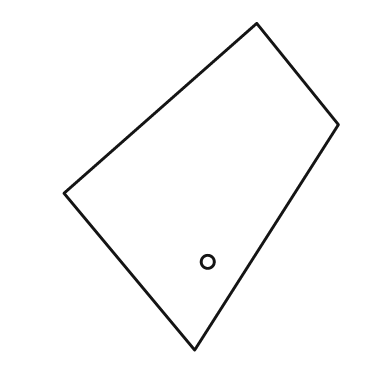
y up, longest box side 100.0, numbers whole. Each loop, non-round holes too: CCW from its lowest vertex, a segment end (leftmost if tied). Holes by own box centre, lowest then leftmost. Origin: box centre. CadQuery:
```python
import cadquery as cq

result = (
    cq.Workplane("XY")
    .moveTo(-2.0, -50.0)
    .lineTo(42.0, 19.0)
    .lineTo(17.0, 50.0)
    .lineTo(-42.0, -2.0)
    .close()
    .moveTo(2.0, -23.0)
    .circle(2.0)
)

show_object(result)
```